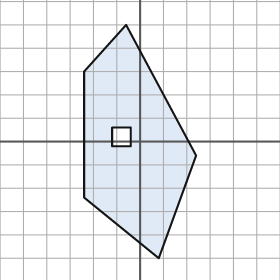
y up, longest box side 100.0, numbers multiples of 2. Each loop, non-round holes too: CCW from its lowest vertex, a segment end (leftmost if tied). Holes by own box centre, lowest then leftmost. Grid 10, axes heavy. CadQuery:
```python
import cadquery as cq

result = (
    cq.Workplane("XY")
    .moveTo(8.0, -50.0)
    .lineTo(24.0, -6.0)
    .lineTo(-6.0, 50.0)
    .lineTo(-24.0, 30.0)
    .lineTo(-24.0, -24.0)
    .close()
    .moveTo(-12.0, -2.0)
    .lineTo(-4.0, -2.0)
    .lineTo(-4.0, 6.0)
    .lineTo(-12.0, 6.0)
    .close()
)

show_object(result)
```